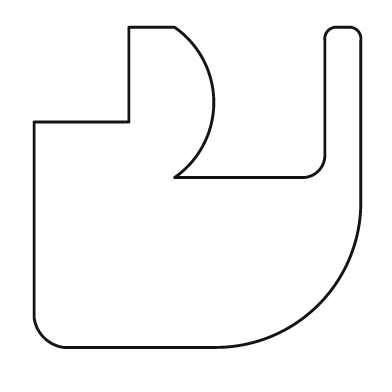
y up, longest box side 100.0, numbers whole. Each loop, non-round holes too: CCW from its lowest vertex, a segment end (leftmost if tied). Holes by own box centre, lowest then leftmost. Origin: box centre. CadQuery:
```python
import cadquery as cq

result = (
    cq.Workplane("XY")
    .moveTo(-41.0, -49.0)
    .lineTo(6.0, -49.0)
    .threePointArc((37.0, -36.0), (50.0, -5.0))
    .lineTo(50.0, 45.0)
    .threePointArc((49.0, 48.0), (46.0, 49.0))
    .lineTo(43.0, 49.0)
    .threePointArc((40.0, 48.0), (39.0, 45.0))
    .lineTo(39.0, 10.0)
    .threePointArc((37.0, 5.0), (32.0, 3.0))
    .lineTo(-7.0, 3.0)
    .threePointArc((5.0, 26.0), (-7.0, 49.0))
    .lineTo(-21.0, 49.0)
    .lineTo(-21.0, 20.0)
    .lineTo(-50.0, 20.0)
    .lineTo(-50.0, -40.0)
    .threePointArc((-47.0, -46.0), (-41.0, -49.0))
    .close()
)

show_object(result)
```